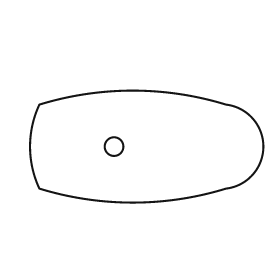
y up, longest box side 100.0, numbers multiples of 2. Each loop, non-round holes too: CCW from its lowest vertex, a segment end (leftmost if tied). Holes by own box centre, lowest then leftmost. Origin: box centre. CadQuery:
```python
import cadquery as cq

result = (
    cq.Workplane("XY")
    .moveTo(-46.0, -18.0)
    .threePointArc((-6.0, -24.0), (34.0, -18.0))
    .threePointArc((50.0, 0.0), (34.0, 18.0))
    .threePointArc((-6.0, 24.0), (-46.0, 18.0))
    .threePointArc((-50.0, 0.0), (-46.0, -18.0))
    .close()
    .moveTo(-14.0, 0.0)
    .circle(4.0)
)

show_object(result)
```